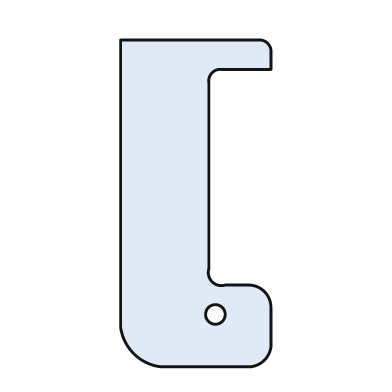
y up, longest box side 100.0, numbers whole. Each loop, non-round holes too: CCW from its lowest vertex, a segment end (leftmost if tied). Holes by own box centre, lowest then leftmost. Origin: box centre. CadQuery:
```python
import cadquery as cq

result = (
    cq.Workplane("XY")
    .moveTo(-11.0, -50.0)
    .lineTo(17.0, -50.0)
    .threePointArc((21.0, -48.0), (23.0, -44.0))
    .lineTo(23.0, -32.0)
    .threePointArc((21.0, -27.0), (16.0, -25.0))
    .lineTo(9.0, -25.0)
    .threePointArc((5.0, -24.0), (4.0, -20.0))
    .lineTo(4.0, 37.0)
    .threePointArc((5.0, 40.0), (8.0, 41.0))
    .lineTo(23.0, 41.0)
    .lineTo(23.0, 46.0)
    .threePointArc((22.0, 49.0), (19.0, 50.0))
    .lineTo(-23.0, 50.0)
    .lineTo(-23.0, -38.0)
    .threePointArc((-19.0, -46.0), (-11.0, -50.0))
    .close()
    .moveTo(6.0, -34.0)
    .circle(3.0)
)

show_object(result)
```